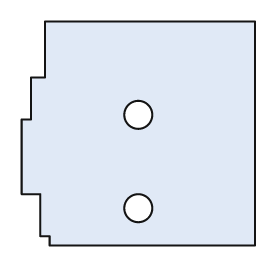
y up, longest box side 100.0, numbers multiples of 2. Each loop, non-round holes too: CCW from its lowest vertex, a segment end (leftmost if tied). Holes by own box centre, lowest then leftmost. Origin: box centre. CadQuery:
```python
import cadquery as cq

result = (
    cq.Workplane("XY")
    .moveTo(-38.0, -48.0)
    .lineTo(50.0, -48.0)
    .lineTo(50.0, 48.0)
    .lineTo(-40.0, 48.0)
    .lineTo(-40.0, 24.0)
    .lineTo(-46.0, 24.0)
    .lineTo(-46.0, 6.0)
    .lineTo(-50.0, 6.0)
    .lineTo(-50.0, -26.0)
    .lineTo(-42.0, -26.0)
    .lineTo(-42.0, -44.0)
    .lineTo(-38.0, -44.0)
    .close()
    .moveTo(0.0, -32.0)
    .circle(6.0)
    .moveTo(0.0, 8.0)
    .circle(6.0)
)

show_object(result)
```